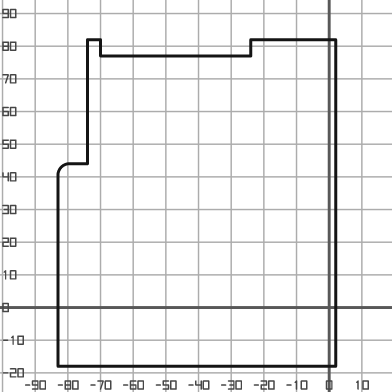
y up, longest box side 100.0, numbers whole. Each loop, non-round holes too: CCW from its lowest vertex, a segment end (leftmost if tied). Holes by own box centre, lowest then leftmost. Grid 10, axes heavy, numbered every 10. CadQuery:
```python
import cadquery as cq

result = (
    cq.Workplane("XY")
    .moveTo(-83.0, -18.0)
    .lineTo(2.0, -18.0)
    .lineTo(2.0, 82.0)
    .lineTo(-24.0, 82.0)
    .lineTo(-24.0, 77.0)
    .lineTo(-70.0, 77.0)
    .lineTo(-70.0, 82.0)
    .lineTo(-74.0, 82.0)
    .lineTo(-74.0, 44.0)
    .lineTo(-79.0, 44.0)
    .threePointArc((-82.0, 43.0), (-83.0, 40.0))
    .close()
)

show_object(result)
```